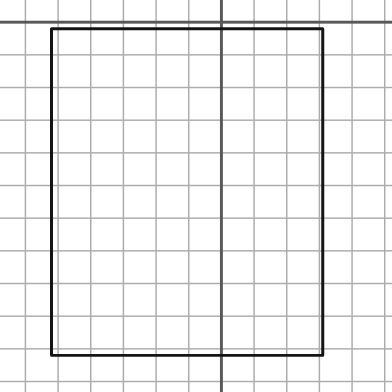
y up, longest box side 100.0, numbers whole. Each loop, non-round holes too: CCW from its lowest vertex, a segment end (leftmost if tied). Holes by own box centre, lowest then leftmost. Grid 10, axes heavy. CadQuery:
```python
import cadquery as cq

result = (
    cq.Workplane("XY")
    .moveTo(-52.0, -102.0)
    .lineTo(31.0, -102.0)
    .lineTo(31.0, -2.0)
    .lineTo(-52.0, -2.0)
    .close()
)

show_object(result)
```